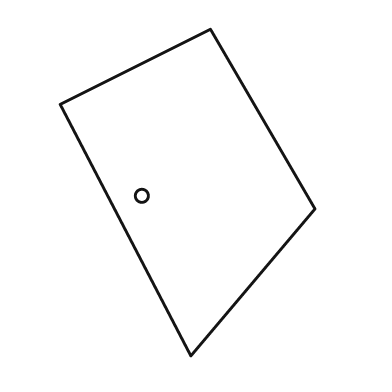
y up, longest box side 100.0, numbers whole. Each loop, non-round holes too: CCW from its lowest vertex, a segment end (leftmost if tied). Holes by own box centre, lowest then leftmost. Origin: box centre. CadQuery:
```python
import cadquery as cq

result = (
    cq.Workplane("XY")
    .moveTo(1.0, -50.0)
    .lineTo(39.0, -5.0)
    .lineTo(7.0, 50.0)
    .lineTo(-39.0, 27.0)
    .close()
    .moveTo(-14.0, -1.0)
    .circle(2.0)
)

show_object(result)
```